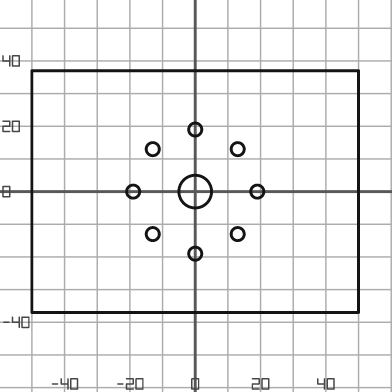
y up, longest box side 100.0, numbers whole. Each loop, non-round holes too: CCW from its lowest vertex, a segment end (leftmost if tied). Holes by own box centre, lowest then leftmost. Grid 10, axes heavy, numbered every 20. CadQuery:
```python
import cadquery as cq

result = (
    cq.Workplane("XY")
    .moveTo(-50.0, -37.0)
    .lineTo(50.0, -37.0)
    .lineTo(50.0, 37.0)
    .lineTo(-50.0, 37.0)
    .close()
    .moveTo(0.0, -19.0)
    .circle(2.0)
    .moveTo(-13.0, -13.0)
    .circle(2.0)
    .moveTo(13.0, -13.0)
    .circle(2.0)
    .moveTo(-19.0, 0.0)
    .circle(2.0)
    .moveTo(0.0, 0.0)
    .circle(5.0)
    .moveTo(19.0, 0.0)
    .circle(2.0)
    .moveTo(-13.0, 13.0)
    .circle(2.0)
    .moveTo(13.0, 13.0)
    .circle(2.0)
    .moveTo(0.0, 19.0)
    .circle(2.0)
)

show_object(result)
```